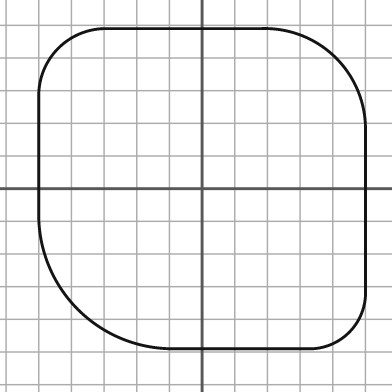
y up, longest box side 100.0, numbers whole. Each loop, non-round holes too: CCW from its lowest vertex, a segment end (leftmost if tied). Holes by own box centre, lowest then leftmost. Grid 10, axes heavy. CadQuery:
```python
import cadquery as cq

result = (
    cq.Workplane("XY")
    .moveTo(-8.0, -49.0)
    .lineTo(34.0, -49.0)
    .threePointArc((45.0, -44.0), (50.0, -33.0))
    .lineTo(50.0, 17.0)
    .threePointArc((41.0, 40.0), (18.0, 49.0))
    .lineTo(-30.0, 49.0)
    .threePointArc((-44.0, 43.0), (-50.0, 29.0))
    .lineTo(-50.0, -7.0)
    .threePointArc((-38.0, -37.0), (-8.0, -49.0))
    .close()
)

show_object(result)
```